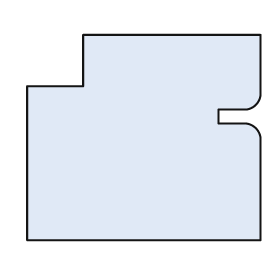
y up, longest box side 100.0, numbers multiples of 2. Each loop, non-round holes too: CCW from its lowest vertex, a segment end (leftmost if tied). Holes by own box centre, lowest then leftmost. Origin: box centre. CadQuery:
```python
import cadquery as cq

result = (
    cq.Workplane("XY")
    .moveTo(-50.0, -44.0)
    .lineTo(50.0, -44.0)
    .lineTo(50.0, 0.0)
    .threePointArc((48.0, 4.0), (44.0, 6.0))
    .lineTo(32.0, 6.0)
    .lineTo(32.0, 12.0)
    .lineTo(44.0, 12.0)
    .threePointArc((48.0, 14.0), (50.0, 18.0))
    .lineTo(50.0, 44.0)
    .lineTo(-26.0, 44.0)
    .lineTo(-26.0, 22.0)
    .lineTo(-50.0, 22.0)
    .close()
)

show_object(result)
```